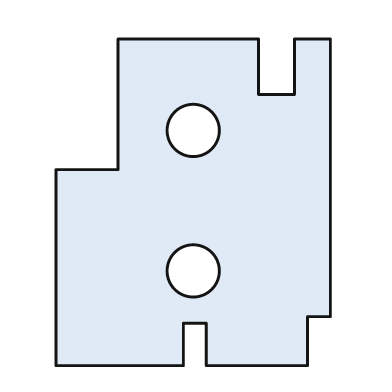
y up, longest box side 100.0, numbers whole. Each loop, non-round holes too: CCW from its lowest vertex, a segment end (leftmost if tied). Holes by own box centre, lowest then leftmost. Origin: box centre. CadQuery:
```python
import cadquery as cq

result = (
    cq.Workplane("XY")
    .moveTo(-42.0, -50.0)
    .lineTo(-3.0, -50.0)
    .lineTo(-3.0, -37.0)
    .lineTo(4.0, -37.0)
    .lineTo(4.0, -50.0)
    .lineTo(35.0, -50.0)
    .lineTo(35.0, -35.0)
    .lineTo(42.0, -35.0)
    .lineTo(42.0, 50.0)
    .lineTo(31.0, 50.0)
    .lineTo(31.0, 33.0)
    .lineTo(20.0, 33.0)
    .lineTo(20.0, 50.0)
    .lineTo(-23.0, 50.0)
    .lineTo(-23.0, 10.0)
    .lineTo(-42.0, 10.0)
    .close()
    .moveTo(0.0, -21.0)
    .circle(8.0)
    .moveTo(0.0, 22.0)
    .circle(8.0)
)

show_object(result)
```